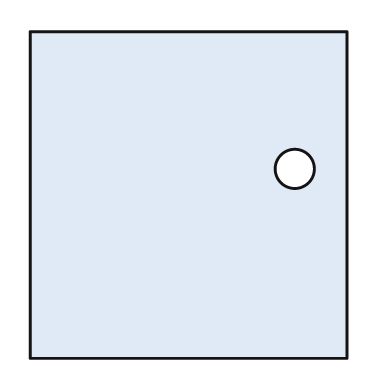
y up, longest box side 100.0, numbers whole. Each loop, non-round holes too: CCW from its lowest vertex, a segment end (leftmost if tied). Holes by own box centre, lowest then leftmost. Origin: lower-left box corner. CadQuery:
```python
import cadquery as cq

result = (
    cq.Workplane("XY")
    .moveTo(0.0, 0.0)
    .lineTo(97.0, 0.0)
    .lineTo(97.0, 100.0)
    .lineTo(0.0, 100.0)
    .close()
    .moveTo(81.0, 58.0)
    .circle(6.0)
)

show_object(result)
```